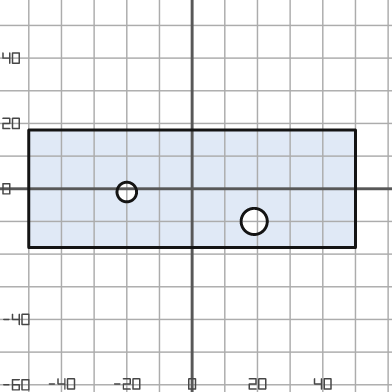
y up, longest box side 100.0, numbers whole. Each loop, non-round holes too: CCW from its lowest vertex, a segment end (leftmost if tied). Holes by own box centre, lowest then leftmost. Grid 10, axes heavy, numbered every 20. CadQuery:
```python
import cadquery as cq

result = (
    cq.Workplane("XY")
    .moveTo(-50.0, -18.0)
    .lineTo(50.0, -18.0)
    .lineTo(50.0, 18.0)
    .lineTo(-50.0, 18.0)
    .close()
    .moveTo(19.0, -10.0)
    .circle(4.0)
    .moveTo(-20.0, -1.0)
    .circle(3.0)
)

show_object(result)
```